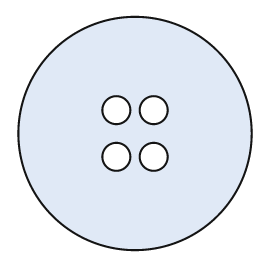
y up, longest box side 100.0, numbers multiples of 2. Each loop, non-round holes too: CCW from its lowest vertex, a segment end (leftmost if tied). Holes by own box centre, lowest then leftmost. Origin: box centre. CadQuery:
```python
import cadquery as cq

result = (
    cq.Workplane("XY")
    .moveTo(0.0, 0.0)
    .circle(50.0)
    .moveTo(-8.0, -10.0)
    .circle(6.0)
    .moveTo(8.0, -10.0)
    .circle(6.0)
    .moveTo(-8.0, 10.0)
    .circle(6.0)
    .moveTo(8.0, 10.0)
    .circle(6.0)
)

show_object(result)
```